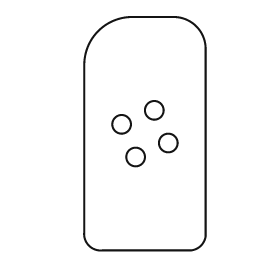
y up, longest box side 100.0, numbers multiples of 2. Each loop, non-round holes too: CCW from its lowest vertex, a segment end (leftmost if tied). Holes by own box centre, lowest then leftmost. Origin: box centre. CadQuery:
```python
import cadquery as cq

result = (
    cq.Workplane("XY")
    .moveTo(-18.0, -50.0)
    .lineTo(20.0, -50.0)
    .threePointArc((24.0, -48.0), (26.0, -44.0))
    .lineTo(26.0, 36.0)
    .threePointArc((22.0, 46.0), (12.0, 50.0))
    .lineTo(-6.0, 50.0)
    .threePointArc((-20.0, 44.0), (-26.0, 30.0))
    .lineTo(-26.0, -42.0)
    .threePointArc((-24.0, -48.0), (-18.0, -50.0))
    .close()
    .moveTo(-4.0, -10.0)
    .circle(4.0)
    .moveTo(10.0, -4.0)
    .circle(4.0)
    .moveTo(-10.0, 4.0)
    .circle(4.0)
    .moveTo(4.0, 10.0)
    .circle(4.0)
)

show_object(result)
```